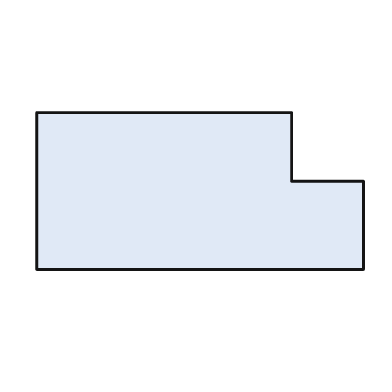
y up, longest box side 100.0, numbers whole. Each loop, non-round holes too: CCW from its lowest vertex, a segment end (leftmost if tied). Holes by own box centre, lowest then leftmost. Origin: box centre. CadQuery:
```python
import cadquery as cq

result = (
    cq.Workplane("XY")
    .moveTo(-50.0, -24.0)
    .lineTo(50.0, -24.0)
    .lineTo(50.0, 3.0)
    .lineTo(28.0, 3.0)
    .lineTo(28.0, 24.0)
    .lineTo(-50.0, 24.0)
    .close()
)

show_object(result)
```